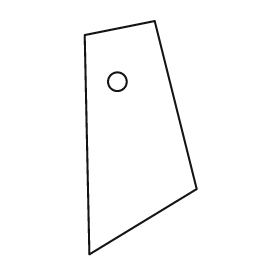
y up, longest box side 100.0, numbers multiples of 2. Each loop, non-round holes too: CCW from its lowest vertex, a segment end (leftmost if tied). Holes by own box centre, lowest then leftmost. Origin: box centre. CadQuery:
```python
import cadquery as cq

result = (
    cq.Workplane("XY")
    .moveTo(-22.0, -50.0)
    .lineTo(24.0, -22.0)
    .lineTo(6.0, 50.0)
    .lineTo(-24.0, 44.0)
    .close()
    .moveTo(-10.0, 24.0)
    .circle(4.0)
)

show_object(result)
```